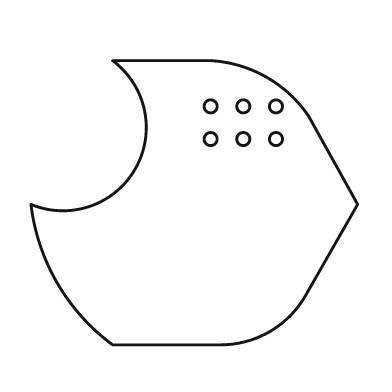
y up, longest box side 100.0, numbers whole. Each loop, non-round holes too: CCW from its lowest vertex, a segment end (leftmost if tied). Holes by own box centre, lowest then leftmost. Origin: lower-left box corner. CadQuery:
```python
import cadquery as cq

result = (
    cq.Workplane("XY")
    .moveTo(25.0, 0.0)
    .lineTo(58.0, 0.0)
    .threePointArc((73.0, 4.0), (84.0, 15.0))
    .lineTo(100.0, 43.0)
    .lineTo(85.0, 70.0)
    .threePointArc((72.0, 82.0), (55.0, 87.0))
    .lineTo(25.0, 87.0)
    .threePointArc((32.0, 54.0), (0.0, 43.0))
    .threePointArc((8.0, 19.0), (25.0, 0.0))
    .close()
    .moveTo(55.0, 63.0)
    .circle(2.0)
    .moveTo(65.0, 63.0)
    .circle(2.0)
    .moveTo(75.0, 63.0)
    .circle(2.0)
    .moveTo(55.0, 73.0)
    .circle(2.0)
    .moveTo(65.0, 73.0)
    .circle(2.0)
    .moveTo(75.0, 73.0)
    .circle(2.0)
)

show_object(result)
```